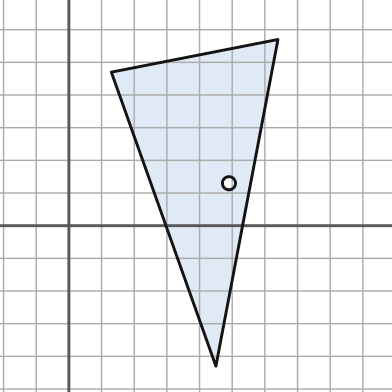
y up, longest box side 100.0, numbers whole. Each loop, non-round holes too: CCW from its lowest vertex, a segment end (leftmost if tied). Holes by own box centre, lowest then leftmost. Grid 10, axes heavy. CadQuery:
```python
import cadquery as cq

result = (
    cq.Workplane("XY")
    .moveTo(45.0, -43.0)
    .lineTo(64.0, 57.0)
    .lineTo(13.0, 47.0)
    .close()
    .moveTo(49.0, 13.0)
    .circle(2.0)
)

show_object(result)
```